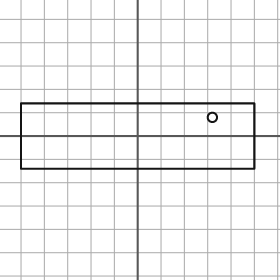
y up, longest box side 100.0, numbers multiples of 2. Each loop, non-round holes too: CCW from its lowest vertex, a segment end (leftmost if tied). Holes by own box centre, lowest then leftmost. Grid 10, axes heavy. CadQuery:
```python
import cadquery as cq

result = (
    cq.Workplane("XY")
    .moveTo(-50.0, -14.0)
    .lineTo(50.0, -14.0)
    .lineTo(50.0, 14.0)
    .lineTo(-50.0, 14.0)
    .close()
    .moveTo(32.0, 8.0)
    .circle(2.0)
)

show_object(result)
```